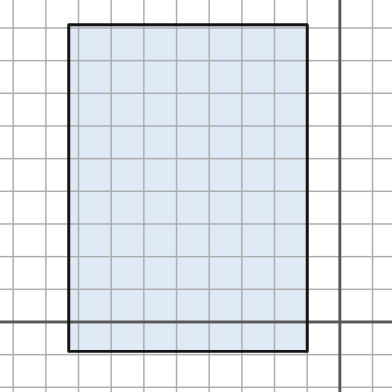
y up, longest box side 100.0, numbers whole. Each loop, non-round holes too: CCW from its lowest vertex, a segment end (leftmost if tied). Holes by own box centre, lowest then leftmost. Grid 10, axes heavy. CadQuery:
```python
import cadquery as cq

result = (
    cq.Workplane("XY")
    .moveTo(-83.0, -9.0)
    .lineTo(-10.0, -9.0)
    .lineTo(-10.0, 91.0)
    .lineTo(-83.0, 91.0)
    .close()
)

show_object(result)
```